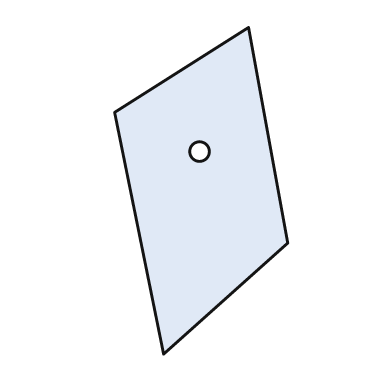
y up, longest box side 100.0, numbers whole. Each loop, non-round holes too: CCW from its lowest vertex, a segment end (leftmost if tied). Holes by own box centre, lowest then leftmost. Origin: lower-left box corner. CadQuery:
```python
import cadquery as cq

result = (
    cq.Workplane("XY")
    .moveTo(15.0, 0.0)
    .lineTo(53.0, 34.0)
    .lineTo(41.0, 100.0)
    .lineTo(0.0, 74.0)
    .close()
    .moveTo(26.0, 62.0)
    .circle(3.0)
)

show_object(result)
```